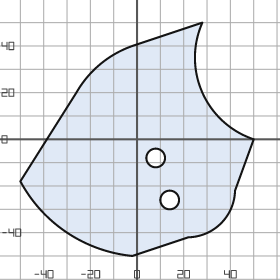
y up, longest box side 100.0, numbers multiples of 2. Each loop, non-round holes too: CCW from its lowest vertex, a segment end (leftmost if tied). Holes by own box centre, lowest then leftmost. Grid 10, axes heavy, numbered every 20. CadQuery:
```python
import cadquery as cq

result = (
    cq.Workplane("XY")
    .moveTo(-2.0, -50.0)
    .lineTo(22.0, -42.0)
    .threePointArc((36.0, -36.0), (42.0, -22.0))
    .lineTo(50.0, 0.0)
    .threePointArc((28.0, 20.0), (28.0, 50.0))
    .lineTo(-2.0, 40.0)
    .threePointArc((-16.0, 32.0), (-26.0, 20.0))
    .lineTo(-50.0, -18.0)
    .threePointArc((-30.0, -40.0), (-2.0, -50.0))
    .close()
    .moveTo(14.0, -26.0)
    .circle(4.0)
    .moveTo(8.0, -8.0)
    .circle(4.0)
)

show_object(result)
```